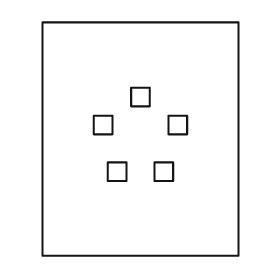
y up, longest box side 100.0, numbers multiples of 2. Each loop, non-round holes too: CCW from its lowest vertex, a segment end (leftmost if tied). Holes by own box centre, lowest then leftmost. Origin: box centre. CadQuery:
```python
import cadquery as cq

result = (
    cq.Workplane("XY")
    .moveTo(-42.0, -50.0)
    .lineTo(42.0, -50.0)
    .lineTo(42.0, 50.0)
    .lineTo(-42.0, 50.0)
    .close()
    .moveTo(-14.0, -18.0)
    .lineTo(-6.0, -18.0)
    .lineTo(-6.0, -10.0)
    .lineTo(-14.0, -10.0)
    .close()
    .moveTo(6.0, -18.0)
    .lineTo(14.0, -18.0)
    .lineTo(14.0, -10.0)
    .lineTo(6.0, -10.0)
    .close()
    .moveTo(-20.0, 2.0)
    .lineTo(-12.0, 2.0)
    .lineTo(-12.0, 10.0)
    .lineTo(-20.0, 10.0)
    .close()
    .moveTo(12.0, 2.0)
    .lineTo(20.0, 2.0)
    .lineTo(20.0, 10.0)
    .lineTo(12.0, 10.0)
    .close()
    .moveTo(-4.0, 14.0)
    .lineTo(4.0, 14.0)
    .lineTo(4.0, 22.0)
    .lineTo(-4.0, 22.0)
    .close()
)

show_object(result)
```